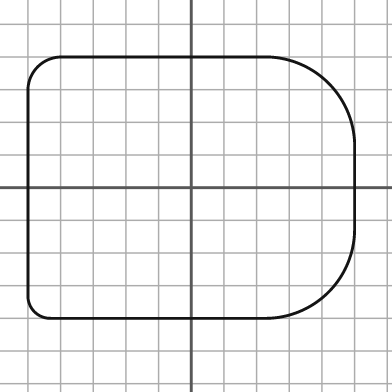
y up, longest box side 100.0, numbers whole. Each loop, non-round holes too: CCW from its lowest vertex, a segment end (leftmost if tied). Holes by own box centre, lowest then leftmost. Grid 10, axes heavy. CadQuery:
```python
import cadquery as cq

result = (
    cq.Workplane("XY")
    .moveTo(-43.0, -40.0)
    .lineTo(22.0, -40.0)
    .threePointArc((42.0, -32.0), (50.0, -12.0))
    .lineTo(50.0, 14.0)
    .threePointArc((42.0, 32.0), (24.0, 40.0))
    .lineTo(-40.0, 40.0)
    .threePointArc((-47.0, 37.0), (-50.0, 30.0))
    .lineTo(-50.0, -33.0)
    .threePointArc((-48.0, -38.0), (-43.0, -40.0))
    .close()
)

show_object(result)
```